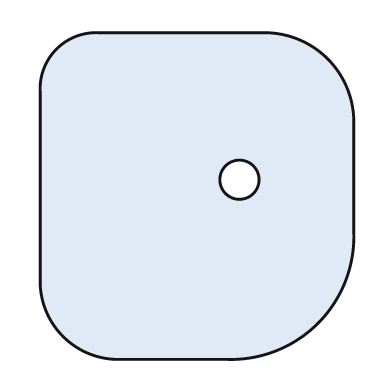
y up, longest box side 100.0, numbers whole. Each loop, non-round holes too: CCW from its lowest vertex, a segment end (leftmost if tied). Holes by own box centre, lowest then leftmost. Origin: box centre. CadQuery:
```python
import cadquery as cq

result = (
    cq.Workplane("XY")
    .moveTo(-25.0, -50.0)
    .lineTo(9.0, -50.0)
    .threePointArc((37.0, -39.0), (48.0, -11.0))
    .lineTo(48.0, 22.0)
    .threePointArc((40.0, 42.0), (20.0, 50.0))
    .lineTo(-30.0, 50.0)
    .threePointArc((-43.0, 45.0), (-48.0, 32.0))
    .lineTo(-48.0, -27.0)
    .threePointArc((-41.0, -43.0), (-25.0, -50.0))
    .close()
    .moveTo(13.0, 5.0)
    .circle(6.0)
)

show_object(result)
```